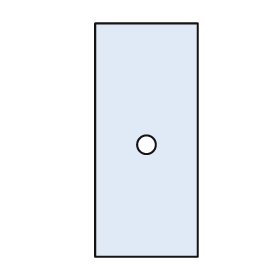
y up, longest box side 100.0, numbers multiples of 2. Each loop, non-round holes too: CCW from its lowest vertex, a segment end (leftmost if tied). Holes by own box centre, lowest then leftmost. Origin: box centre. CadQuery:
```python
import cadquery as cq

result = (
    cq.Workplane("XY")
    .moveTo(-22.0, -50.0)
    .lineTo(22.0, -50.0)
    .lineTo(22.0, 50.0)
    .lineTo(-22.0, 50.0)
    .close()
    .moveTo(0.0, -2.0)
    .circle(4.0)
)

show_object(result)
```